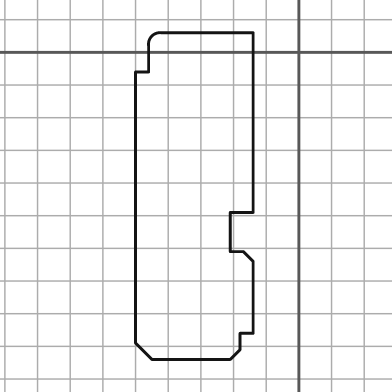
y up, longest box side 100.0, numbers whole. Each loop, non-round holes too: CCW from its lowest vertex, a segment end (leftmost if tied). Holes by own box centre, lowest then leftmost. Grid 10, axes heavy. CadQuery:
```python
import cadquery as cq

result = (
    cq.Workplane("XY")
    .moveTo(-45.0, -94.0)
    .lineTo(-21.0, -94.0)
    .lineTo(-18.0, -91.0)
    .lineTo(-18.0, -86.0)
    .lineTo(-14.0, -86.0)
    .lineTo(-14.0, -64.0)
    .lineTo(-17.0, -61.0)
    .lineTo(-21.0, -61.0)
    .lineTo(-21.0, -49.0)
    .lineTo(-14.0, -49.0)
    .lineTo(-14.0, 6.0)
    .lineTo(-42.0, 6.0)
    .threePointArc((-45.0, 5.0), (-46.0, 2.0))
    .lineTo(-46.0, -6.0)
    .lineTo(-50.0, -6.0)
    .lineTo(-50.0, -89.0)
    .close()
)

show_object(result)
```